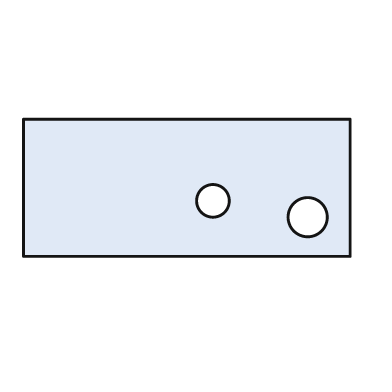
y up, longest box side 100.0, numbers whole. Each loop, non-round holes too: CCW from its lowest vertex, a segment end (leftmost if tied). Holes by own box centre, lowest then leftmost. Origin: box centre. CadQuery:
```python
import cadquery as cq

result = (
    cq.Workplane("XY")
    .moveTo(-50.0, -21.0)
    .lineTo(50.0, -21.0)
    .lineTo(50.0, 21.0)
    .lineTo(-50.0, 21.0)
    .close()
    .moveTo(37.0, -9.0)
    .circle(6.0)
    .moveTo(8.0, -4.0)
    .circle(5.0)
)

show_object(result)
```